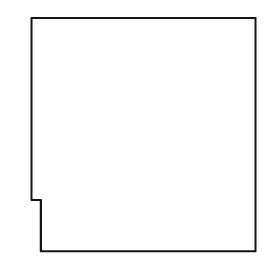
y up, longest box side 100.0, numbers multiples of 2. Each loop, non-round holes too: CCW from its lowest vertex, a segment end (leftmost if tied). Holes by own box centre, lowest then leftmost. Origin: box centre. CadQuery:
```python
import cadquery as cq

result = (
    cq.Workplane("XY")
    .moveTo(-44.0, -50.0)
    .lineTo(48.0, -50.0)
    .lineTo(48.0, 50.0)
    .lineTo(-48.0, 50.0)
    .lineTo(-48.0, -28.0)
    .lineTo(-44.0, -28.0)
    .close()
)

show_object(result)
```